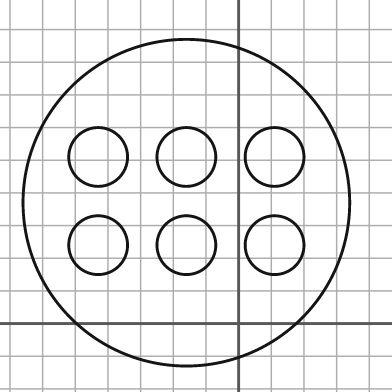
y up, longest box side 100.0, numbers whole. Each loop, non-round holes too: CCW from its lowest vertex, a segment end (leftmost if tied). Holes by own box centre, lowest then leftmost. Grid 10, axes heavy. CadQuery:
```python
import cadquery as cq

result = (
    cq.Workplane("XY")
    .moveTo(-16.0, 37.0)
    .circle(50.0)
    .moveTo(-43.0, 24.0)
    .circle(9.0)
    .moveTo(-16.0, 24.0)
    .circle(9.0)
    .moveTo(11.0, 24.0)
    .circle(9.0)
    .moveTo(-43.0, 51.0)
    .circle(9.0)
    .moveTo(-16.0, 51.0)
    .circle(9.0)
    .moveTo(11.0, 51.0)
    .circle(9.0)
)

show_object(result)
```